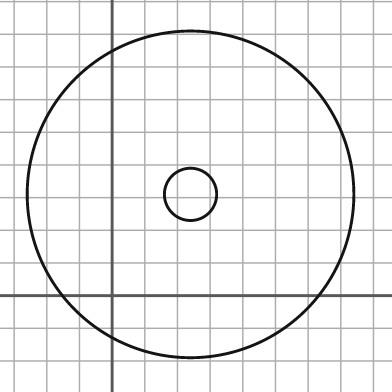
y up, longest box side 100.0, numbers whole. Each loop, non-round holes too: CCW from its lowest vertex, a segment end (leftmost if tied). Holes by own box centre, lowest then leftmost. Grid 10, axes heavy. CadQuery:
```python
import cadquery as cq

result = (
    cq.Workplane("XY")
    .moveTo(24.0, 31.0)
    .circle(50.0)
    .moveTo(24.0, 31.0)
    .circle(8.0)
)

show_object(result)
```